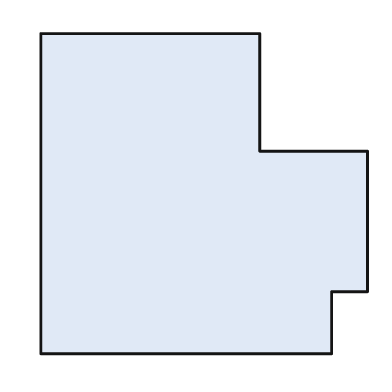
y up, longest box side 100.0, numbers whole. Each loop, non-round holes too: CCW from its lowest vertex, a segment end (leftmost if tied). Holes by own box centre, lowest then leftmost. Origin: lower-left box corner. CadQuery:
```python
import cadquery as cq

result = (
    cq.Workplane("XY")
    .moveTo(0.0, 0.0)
    .lineTo(89.0, 0.0)
    .lineTo(89.0, 19.0)
    .lineTo(100.0, 19.0)
    .lineTo(100.0, 62.0)
    .lineTo(67.0, 62.0)
    .lineTo(67.0, 98.0)
    .lineTo(0.0, 98.0)
    .close()
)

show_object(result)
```